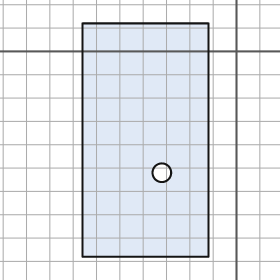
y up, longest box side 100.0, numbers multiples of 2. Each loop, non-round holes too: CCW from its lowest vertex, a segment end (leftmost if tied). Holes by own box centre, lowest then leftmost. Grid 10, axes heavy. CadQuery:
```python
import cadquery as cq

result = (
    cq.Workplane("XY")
    .moveTo(-66.0, -88.0)
    .lineTo(-12.0, -88.0)
    .lineTo(-12.0, 12.0)
    .lineTo(-66.0, 12.0)
    .close()
    .moveTo(-32.0, -52.0)
    .circle(4.0)
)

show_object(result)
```